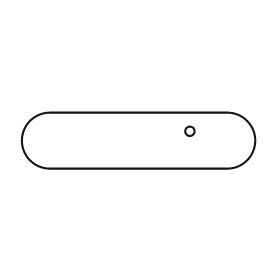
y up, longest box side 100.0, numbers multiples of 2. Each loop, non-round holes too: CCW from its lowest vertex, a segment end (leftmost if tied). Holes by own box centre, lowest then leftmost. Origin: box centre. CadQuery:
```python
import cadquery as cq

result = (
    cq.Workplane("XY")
    .moveTo(-38.0, -12.0)
    .lineTo(38.0, -12.0)
    .threePointArc((50.0, 0.0), (38.0, 12.0))
    .lineTo(-38.0, 12.0)
    .threePointArc((-50.0, 0.0), (-38.0, -12.0))
    .close()
    .moveTo(22.0, 4.0)
    .circle(2.0)
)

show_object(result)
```